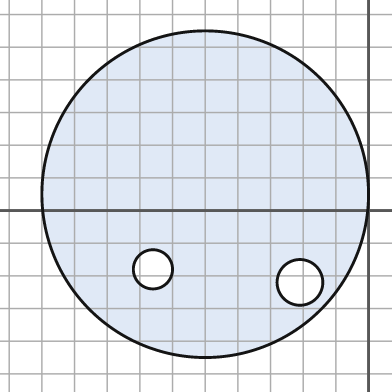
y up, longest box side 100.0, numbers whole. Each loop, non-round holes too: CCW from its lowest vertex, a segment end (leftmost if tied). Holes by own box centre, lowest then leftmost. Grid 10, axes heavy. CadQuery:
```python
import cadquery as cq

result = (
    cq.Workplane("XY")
    .moveTo(-50.0, 5.0)
    .circle(50.0)
    .moveTo(-21.0, -22.0)
    .circle(7.0)
    .moveTo(-66.0, -18.0)
    .circle(6.0)
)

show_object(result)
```